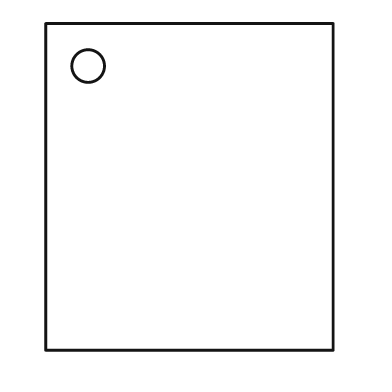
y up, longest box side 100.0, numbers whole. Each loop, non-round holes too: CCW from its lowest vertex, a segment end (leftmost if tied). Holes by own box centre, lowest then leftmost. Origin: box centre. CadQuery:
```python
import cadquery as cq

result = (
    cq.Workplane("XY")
    .moveTo(-44.0, -50.0)
    .lineTo(44.0, -50.0)
    .lineTo(44.0, 50.0)
    .lineTo(-44.0, 50.0)
    .close()
    .moveTo(-31.0, 37.0)
    .circle(5.0)
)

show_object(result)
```